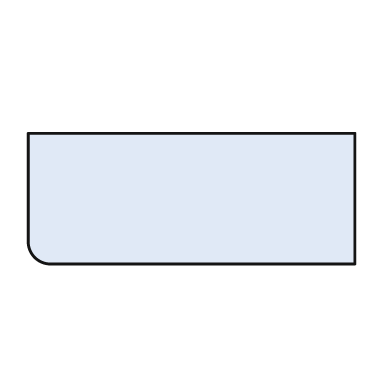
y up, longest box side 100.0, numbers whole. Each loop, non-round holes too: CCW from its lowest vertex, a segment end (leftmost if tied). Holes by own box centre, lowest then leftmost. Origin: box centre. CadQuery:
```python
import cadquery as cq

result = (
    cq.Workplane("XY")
    .moveTo(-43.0, -20.0)
    .lineTo(50.0, -20.0)
    .lineTo(50.0, 20.0)
    .lineTo(-50.0, 20.0)
    .lineTo(-50.0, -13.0)
    .threePointArc((-48.0, -18.0), (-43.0, -20.0))
    .close()
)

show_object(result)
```